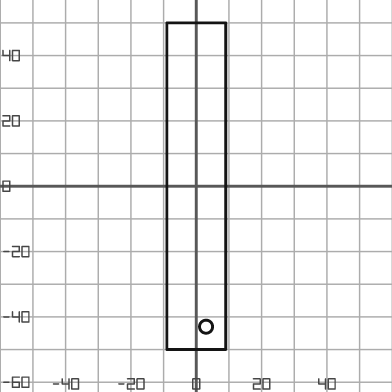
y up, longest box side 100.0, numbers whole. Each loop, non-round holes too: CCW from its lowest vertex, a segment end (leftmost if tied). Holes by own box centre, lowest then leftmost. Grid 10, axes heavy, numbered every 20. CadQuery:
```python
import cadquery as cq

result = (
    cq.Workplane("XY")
    .moveTo(-9.0, -50.0)
    .lineTo(9.0, -50.0)
    .lineTo(9.0, 50.0)
    .lineTo(-9.0, 50.0)
    .close()
    .moveTo(3.0, -43.0)
    .circle(2.0)
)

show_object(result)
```